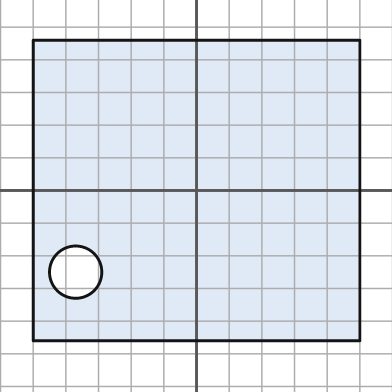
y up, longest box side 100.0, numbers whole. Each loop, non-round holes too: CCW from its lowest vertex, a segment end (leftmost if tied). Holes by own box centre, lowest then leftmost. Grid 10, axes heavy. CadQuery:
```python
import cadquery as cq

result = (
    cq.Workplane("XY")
    .moveTo(-50.0, -46.0)
    .lineTo(50.0, -46.0)
    .lineTo(50.0, 46.0)
    .lineTo(-50.0, 46.0)
    .close()
    .moveTo(-37.0, -25.0)
    .circle(8.0)
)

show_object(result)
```